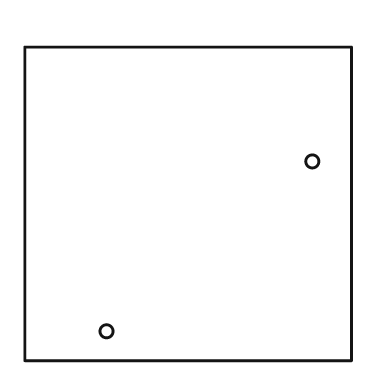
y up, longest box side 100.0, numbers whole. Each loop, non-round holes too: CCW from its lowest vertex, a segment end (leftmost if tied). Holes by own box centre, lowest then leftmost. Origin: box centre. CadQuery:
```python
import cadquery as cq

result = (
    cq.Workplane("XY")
    .moveTo(-50.0, -48.0)
    .lineTo(50.0, -48.0)
    .lineTo(50.0, 48.0)
    .lineTo(-50.0, 48.0)
    .close()
    .moveTo(-25.0, -39.0)
    .circle(2.0)
    .moveTo(38.0, 13.0)
    .circle(2.0)
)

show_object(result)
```